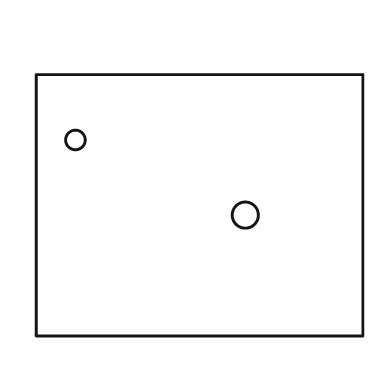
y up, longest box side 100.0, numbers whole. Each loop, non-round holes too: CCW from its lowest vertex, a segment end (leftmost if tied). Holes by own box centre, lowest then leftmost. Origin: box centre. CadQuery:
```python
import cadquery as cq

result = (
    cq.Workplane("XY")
    .moveTo(-50.0, -40.0)
    .lineTo(50.0, -40.0)
    .lineTo(50.0, 40.0)
    .lineTo(-50.0, 40.0)
    .close()
    .moveTo(14.0, -3.0)
    .circle(4.0)
    .moveTo(-38.0, 20.0)
    .circle(3.0)
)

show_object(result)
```